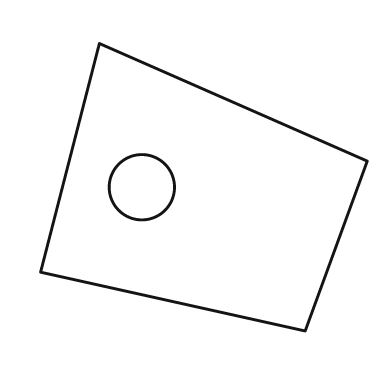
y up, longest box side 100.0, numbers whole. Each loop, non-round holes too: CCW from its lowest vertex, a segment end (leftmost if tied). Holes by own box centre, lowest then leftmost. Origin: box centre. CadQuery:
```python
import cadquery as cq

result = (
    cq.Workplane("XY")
    .moveTo(31.0, -44.0)
    .lineTo(50.0, 8.0)
    .lineTo(-32.0, 44.0)
    .lineTo(-50.0, -26.0)
    .close()
    .moveTo(-19.0, 0.0)
    .circle(10.0)
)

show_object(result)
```